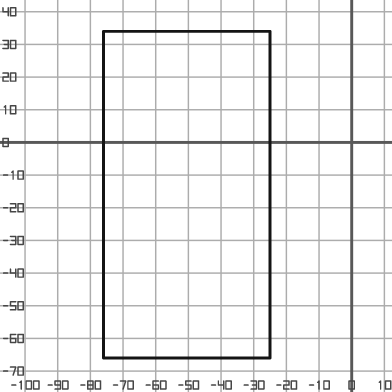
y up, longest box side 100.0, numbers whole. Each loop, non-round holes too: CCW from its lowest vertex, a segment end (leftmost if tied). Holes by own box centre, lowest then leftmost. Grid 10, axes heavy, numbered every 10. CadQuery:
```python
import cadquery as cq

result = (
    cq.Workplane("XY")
    .moveTo(-76.0, -66.0)
    .lineTo(-25.0, -66.0)
    .lineTo(-25.0, 34.0)
    .lineTo(-76.0, 34.0)
    .close()
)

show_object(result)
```